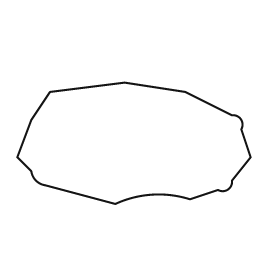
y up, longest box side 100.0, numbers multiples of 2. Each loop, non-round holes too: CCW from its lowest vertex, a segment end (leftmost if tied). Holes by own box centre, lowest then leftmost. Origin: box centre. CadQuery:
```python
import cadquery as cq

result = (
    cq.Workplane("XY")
    .moveTo(-8.0, -26.0)
    .threePointArc((8.0, -22.0), (24.0, -24.0))
    .lineTo(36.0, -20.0)
    .threePointArc((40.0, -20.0), (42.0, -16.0))
    .lineTo(50.0, -6.0)
    .lineTo(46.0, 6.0)
    .threePointArc((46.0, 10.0), (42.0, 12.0))
    .lineTo(22.0, 22.0)
    .lineTo(-4.0, 26.0)
    .lineTo(-36.0, 22.0)
    .lineTo(-44.0, 10.0)
    .lineTo(-50.0, -6.0)
    .lineTo(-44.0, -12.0)
    .threePointArc((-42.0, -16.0), (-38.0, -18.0))
    .close()
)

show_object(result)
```